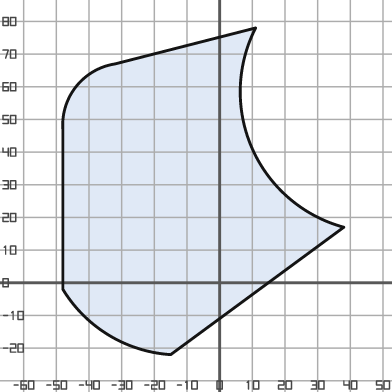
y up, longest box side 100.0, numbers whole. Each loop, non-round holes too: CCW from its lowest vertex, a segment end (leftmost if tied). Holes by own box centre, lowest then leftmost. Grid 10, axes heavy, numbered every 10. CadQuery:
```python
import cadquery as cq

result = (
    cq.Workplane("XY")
    .moveTo(-15.0, -22.0)
    .lineTo(38.0, 17.0)
    .threePointArc((10.0, 41.0), (11.0, 78.0))
    .lineTo(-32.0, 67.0)
    .threePointArc((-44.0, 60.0), (-48.0, 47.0))
    .lineTo(-48.0, -2.0)
    .threePointArc((-34.0, -16.0), (-15.0, -22.0))
    .close()
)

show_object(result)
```